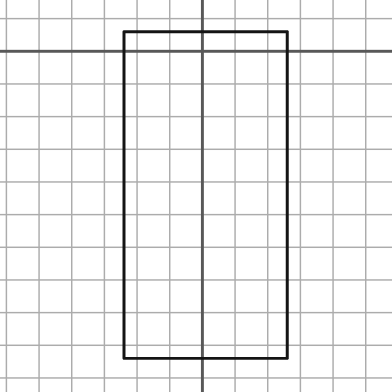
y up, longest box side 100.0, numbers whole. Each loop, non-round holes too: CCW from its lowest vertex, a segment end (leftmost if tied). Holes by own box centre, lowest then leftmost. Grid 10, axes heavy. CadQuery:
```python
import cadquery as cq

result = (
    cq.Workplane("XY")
    .moveTo(-24.0, -94.0)
    .lineTo(26.0, -94.0)
    .lineTo(26.0, 6.0)
    .lineTo(-24.0, 6.0)
    .close()
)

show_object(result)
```